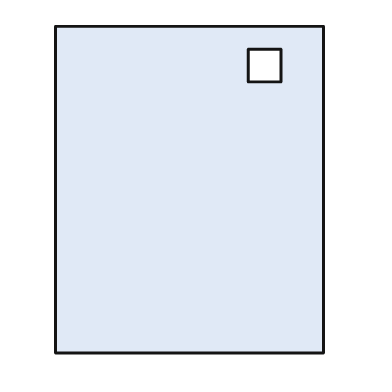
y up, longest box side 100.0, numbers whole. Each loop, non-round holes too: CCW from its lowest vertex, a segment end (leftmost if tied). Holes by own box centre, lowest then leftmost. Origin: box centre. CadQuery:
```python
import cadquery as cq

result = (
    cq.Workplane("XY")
    .moveTo(-41.0, -50.0)
    .lineTo(41.0, -50.0)
    .lineTo(41.0, 50.0)
    .lineTo(-41.0, 50.0)
    .close()
    .moveTo(18.0, 33.0)
    .lineTo(28.0, 33.0)
    .lineTo(28.0, 43.0)
    .lineTo(18.0, 43.0)
    .close()
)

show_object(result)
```